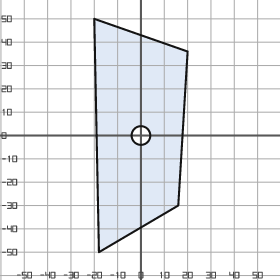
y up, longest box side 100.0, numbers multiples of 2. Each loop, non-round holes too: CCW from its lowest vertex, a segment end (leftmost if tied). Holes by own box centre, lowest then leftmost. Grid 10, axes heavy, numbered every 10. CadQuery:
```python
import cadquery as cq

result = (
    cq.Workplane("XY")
    .moveTo(-18.0, -50.0)
    .lineTo(16.0, -30.0)
    .lineTo(20.0, 36.0)
    .lineTo(-20.0, 50.0)
    .close()
    .moveTo(0.0, 0.0)
    .circle(4.0)
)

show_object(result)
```